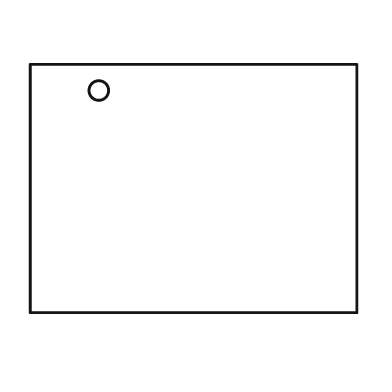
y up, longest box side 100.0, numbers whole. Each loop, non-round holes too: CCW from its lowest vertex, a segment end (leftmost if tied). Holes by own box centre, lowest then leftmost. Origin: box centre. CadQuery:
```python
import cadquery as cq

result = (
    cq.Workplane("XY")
    .moveTo(-50.0, -38.0)
    .lineTo(50.0, -38.0)
    .lineTo(50.0, 38.0)
    .lineTo(-50.0, 38.0)
    .close()
    .moveTo(-29.0, 30.0)
    .circle(3.0)
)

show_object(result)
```